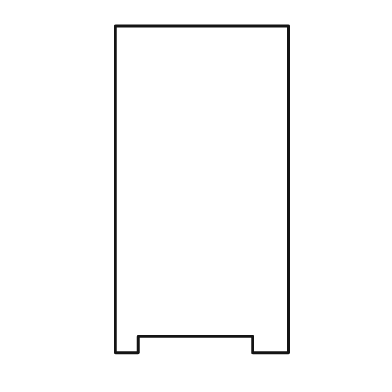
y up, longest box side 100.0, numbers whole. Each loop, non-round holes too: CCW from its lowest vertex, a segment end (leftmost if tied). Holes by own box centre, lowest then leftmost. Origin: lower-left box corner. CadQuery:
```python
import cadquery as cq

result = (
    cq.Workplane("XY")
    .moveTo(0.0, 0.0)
    .lineTo(7.0, 0.0)
    .lineTo(7.0, 5.0)
    .lineTo(42.0, 5.0)
    .lineTo(42.0, 0.0)
    .lineTo(53.0, 0.0)
    .lineTo(53.0, 100.0)
    .lineTo(0.0, 100.0)
    .close()
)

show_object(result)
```